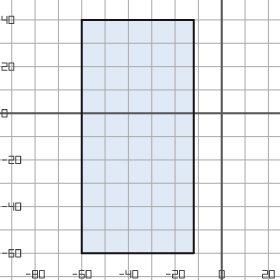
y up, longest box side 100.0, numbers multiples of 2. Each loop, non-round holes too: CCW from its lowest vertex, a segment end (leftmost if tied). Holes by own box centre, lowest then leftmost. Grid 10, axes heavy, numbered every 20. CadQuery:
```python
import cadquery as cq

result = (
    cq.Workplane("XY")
    .moveTo(-60.0, -60.0)
    .lineTo(-12.0, -60.0)
    .lineTo(-12.0, 40.0)
    .lineTo(-60.0, 40.0)
    .close()
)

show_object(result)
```